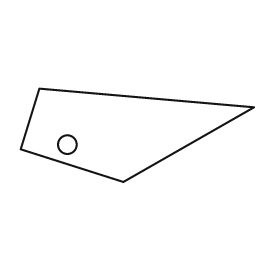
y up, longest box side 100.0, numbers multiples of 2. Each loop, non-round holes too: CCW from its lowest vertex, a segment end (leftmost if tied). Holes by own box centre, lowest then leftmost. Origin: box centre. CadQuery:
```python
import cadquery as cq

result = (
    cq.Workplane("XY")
    .moveTo(-6.0, -20.0)
    .lineTo(50.0, 12.0)
    .lineTo(-42.0, 20.0)
    .lineTo(-50.0, -6.0)
    .close()
    .moveTo(-30.0, -4.0)
    .circle(4.0)
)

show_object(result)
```